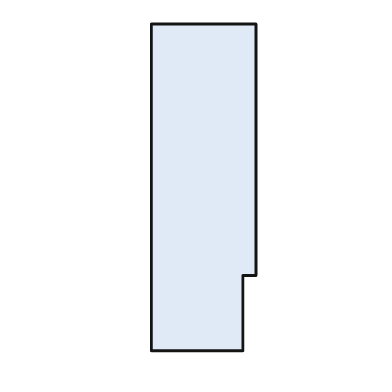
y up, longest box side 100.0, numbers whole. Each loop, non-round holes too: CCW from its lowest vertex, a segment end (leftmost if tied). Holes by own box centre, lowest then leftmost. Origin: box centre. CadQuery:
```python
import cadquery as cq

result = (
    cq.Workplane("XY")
    .moveTo(-16.0, -50.0)
    .lineTo(12.0, -50.0)
    .lineTo(12.0, -27.0)
    .lineTo(16.0, -27.0)
    .lineTo(16.0, 50.0)
    .lineTo(-16.0, 50.0)
    .close()
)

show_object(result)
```